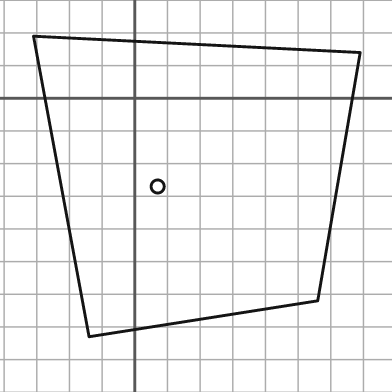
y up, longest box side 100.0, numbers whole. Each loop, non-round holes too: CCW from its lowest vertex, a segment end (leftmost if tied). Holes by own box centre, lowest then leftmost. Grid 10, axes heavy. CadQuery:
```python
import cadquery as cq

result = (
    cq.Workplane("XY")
    .moveTo(-14.0, -73.0)
    .lineTo(56.0, -62.0)
    .lineTo(69.0, 14.0)
    .lineTo(-31.0, 19.0)
    .close()
    .moveTo(7.0, -27.0)
    .circle(2.0)
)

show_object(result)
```